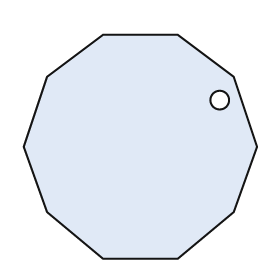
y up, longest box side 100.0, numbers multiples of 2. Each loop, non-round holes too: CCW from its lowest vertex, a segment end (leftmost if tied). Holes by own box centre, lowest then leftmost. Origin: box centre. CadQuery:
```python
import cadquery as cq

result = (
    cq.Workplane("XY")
    .moveTo(-16.0, -48.0)
    .lineTo(16.0, -48.0)
    .lineTo(40.0, -28.0)
    .lineTo(50.0, 0.0)
    .lineTo(40.0, 30.0)
    .lineTo(16.0, 48.0)
    .lineTo(-16.0, 48.0)
    .lineTo(-40.0, 30.0)
    .lineTo(-50.0, 0.0)
    .lineTo(-40.0, -28.0)
    .close()
    .moveTo(34.0, 20.0)
    .circle(4.0)
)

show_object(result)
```